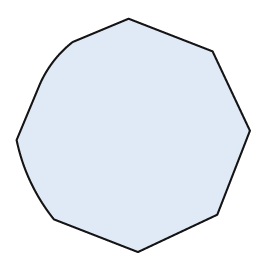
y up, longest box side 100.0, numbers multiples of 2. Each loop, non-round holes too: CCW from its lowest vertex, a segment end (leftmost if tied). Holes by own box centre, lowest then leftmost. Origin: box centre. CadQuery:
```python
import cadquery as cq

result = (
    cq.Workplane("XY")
    .moveTo(2.0, -50.0)
    .lineTo(36.0, -34.0)
    .lineTo(50.0, 2.0)
    .lineTo(34.0, 36.0)
    .lineTo(-2.0, 50.0)
    .lineTo(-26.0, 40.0)
    .threePointArc((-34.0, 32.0), (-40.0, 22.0))
    .lineTo(-50.0, -2.0)
    .threePointArc((-44.0, -20.0), (-34.0, -36.0))
    .close()
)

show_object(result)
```